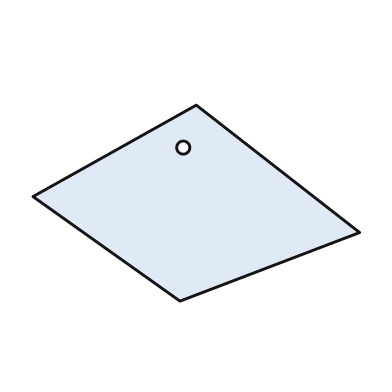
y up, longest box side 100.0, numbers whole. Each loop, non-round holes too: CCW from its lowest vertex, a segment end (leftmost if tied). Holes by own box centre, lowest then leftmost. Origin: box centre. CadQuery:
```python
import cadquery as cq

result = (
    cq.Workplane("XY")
    .moveTo(-5.0, -30.0)
    .lineTo(50.0, -9.0)
    .lineTo(0.0, 30.0)
    .lineTo(-50.0, 2.0)
    .close()
    .moveTo(-4.0, 17.0)
    .circle(2.0)
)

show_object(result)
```